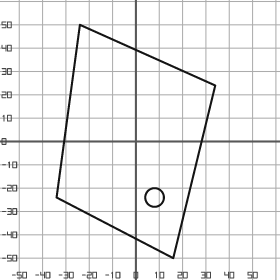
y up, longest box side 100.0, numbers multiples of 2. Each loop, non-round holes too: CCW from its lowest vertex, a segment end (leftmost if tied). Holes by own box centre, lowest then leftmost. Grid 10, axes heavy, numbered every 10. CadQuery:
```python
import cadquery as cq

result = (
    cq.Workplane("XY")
    .moveTo(16.0, -50.0)
    .lineTo(34.0, 24.0)
    .lineTo(-24.0, 50.0)
    .lineTo(-34.0, -24.0)
    .close()
    .moveTo(8.0, -24.0)
    .circle(4.0)
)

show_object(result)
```